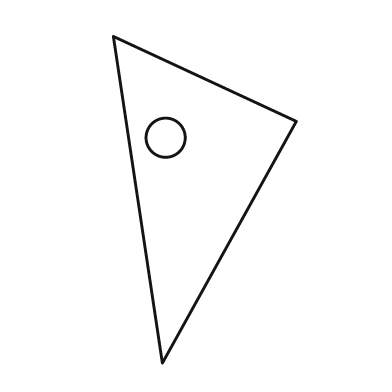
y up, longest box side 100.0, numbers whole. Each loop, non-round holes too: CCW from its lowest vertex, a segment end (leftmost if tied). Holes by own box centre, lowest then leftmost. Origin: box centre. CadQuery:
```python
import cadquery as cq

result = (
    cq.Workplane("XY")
    .moveTo(-13.0, -50.0)
    .lineTo(28.0, 24.0)
    .lineTo(-28.0, 50.0)
    .close()
    .moveTo(-12.0, 19.0)
    .circle(6.0)
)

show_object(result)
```